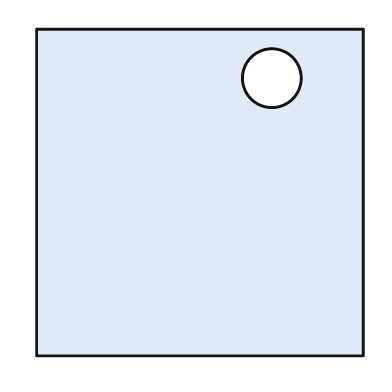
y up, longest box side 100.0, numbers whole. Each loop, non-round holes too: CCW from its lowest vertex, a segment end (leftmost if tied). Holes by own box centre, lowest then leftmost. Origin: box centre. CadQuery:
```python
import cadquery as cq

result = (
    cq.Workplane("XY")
    .moveTo(-50.0, -50.0)
    .lineTo(50.0, -50.0)
    .lineTo(50.0, 50.0)
    .lineTo(-50.0, 50.0)
    .close()
    .moveTo(22.0, 35.0)
    .circle(9.0)
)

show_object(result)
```